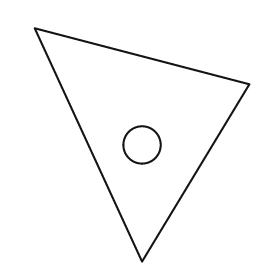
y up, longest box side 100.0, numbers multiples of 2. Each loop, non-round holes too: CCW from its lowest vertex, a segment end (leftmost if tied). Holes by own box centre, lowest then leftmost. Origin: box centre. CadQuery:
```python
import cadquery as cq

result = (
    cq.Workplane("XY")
    .moveTo(0.0, -50.0)
    .lineTo(46.0, 26.0)
    .lineTo(-46.0, 50.0)
    .close()
    .moveTo(0.0, 0.0)
    .circle(8.0)
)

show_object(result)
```